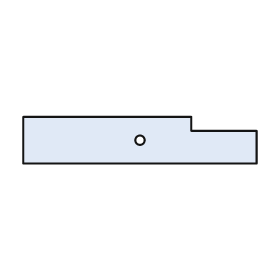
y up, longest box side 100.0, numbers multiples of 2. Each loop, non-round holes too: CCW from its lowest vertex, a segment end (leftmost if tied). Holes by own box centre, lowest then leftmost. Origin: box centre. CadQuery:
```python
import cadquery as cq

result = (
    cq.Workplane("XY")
    .moveTo(-50.0, -10.0)
    .lineTo(50.0, -10.0)
    .lineTo(50.0, 4.0)
    .lineTo(22.0, 4.0)
    .lineTo(22.0, 10.0)
    .lineTo(-50.0, 10.0)
    .close()
    .moveTo(0.0, 0.0)
    .circle(2.0)
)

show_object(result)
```